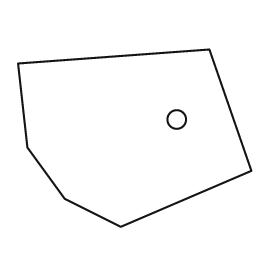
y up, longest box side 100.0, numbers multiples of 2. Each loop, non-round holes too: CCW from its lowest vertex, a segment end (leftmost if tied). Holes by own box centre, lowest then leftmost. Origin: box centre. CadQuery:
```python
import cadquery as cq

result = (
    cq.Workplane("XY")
    .moveTo(-6.0, -38.0)
    .lineTo(50.0, -14.0)
    .lineTo(32.0, 38.0)
    .lineTo(-50.0, 32.0)
    .lineTo(-46.0, -4.0)
    .lineTo(-30.0, -26.0)
    .close()
    .moveTo(18.0, 8.0)
    .circle(4.0)
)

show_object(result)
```